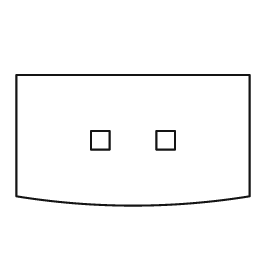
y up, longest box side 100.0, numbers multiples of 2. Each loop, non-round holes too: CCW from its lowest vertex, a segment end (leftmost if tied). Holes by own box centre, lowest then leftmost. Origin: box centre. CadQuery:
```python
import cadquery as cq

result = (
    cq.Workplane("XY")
    .moveTo(-50.0, -24.0)
    .threePointArc((0.0, -28.0), (50.0, -24.0))
    .lineTo(50.0, 28.0)
    .lineTo(-50.0, 28.0)
    .close()
    .moveTo(-18.0, -4.0)
    .lineTo(-10.0, -4.0)
    .lineTo(-10.0, 4.0)
    .lineTo(-18.0, 4.0)
    .close()
    .moveTo(10.0, -4.0)
    .lineTo(18.0, -4.0)
    .lineTo(18.0, 4.0)
    .lineTo(10.0, 4.0)
    .close()
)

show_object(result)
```